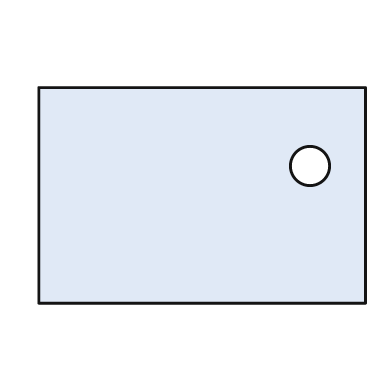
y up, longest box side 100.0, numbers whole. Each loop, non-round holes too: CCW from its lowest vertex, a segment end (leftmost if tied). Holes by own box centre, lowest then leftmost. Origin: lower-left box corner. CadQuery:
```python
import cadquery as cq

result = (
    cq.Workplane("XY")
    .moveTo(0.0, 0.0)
    .lineTo(100.0, 0.0)
    .lineTo(100.0, 66.0)
    .lineTo(0.0, 66.0)
    .close()
    .moveTo(83.0, 42.0)
    .circle(6.0)
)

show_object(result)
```